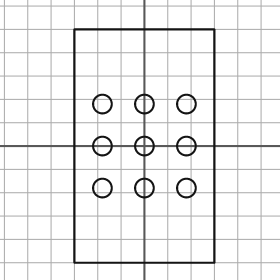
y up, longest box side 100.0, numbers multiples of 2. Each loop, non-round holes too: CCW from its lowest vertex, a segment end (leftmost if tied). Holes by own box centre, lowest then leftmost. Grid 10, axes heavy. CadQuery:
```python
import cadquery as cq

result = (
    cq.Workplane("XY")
    .moveTo(-30.0, -50.0)
    .lineTo(30.0, -50.0)
    .lineTo(30.0, 50.0)
    .lineTo(-30.0, 50.0)
    .close()
    .moveTo(-18.0, -18.0)
    .circle(4.0)
    .moveTo(0.0, -18.0)
    .circle(4.0)
    .moveTo(18.0, -18.0)
    .circle(4.0)
    .moveTo(-18.0, 0.0)
    .circle(4.0)
    .moveTo(0.0, 0.0)
    .circle(4.0)
    .moveTo(18.0, 0.0)
    .circle(4.0)
    .moveTo(-18.0, 18.0)
    .circle(4.0)
    .moveTo(0.0, 18.0)
    .circle(4.0)
    .moveTo(18.0, 18.0)
    .circle(4.0)
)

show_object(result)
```